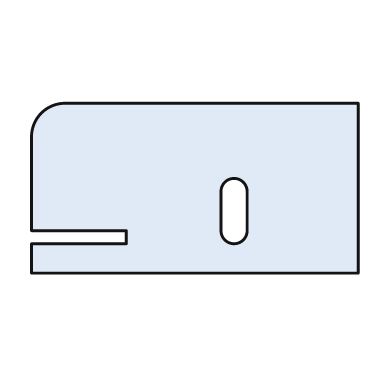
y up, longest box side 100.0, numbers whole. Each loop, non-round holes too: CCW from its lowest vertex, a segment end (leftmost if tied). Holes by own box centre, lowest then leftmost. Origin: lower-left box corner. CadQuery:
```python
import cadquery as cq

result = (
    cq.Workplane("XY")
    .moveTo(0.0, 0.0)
    .lineTo(100.0, 0.0)
    .lineTo(100.0, 52.0)
    .lineTo(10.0, 52.0)
    .threePointArc((3.0, 49.0), (0.0, 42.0))
    .lineTo(0.0, 13.0)
    .lineTo(29.0, 13.0)
    .lineTo(29.0, 9.0)
    .lineTo(0.0, 9.0)
    .close()
    .moveTo(58.0, 13.0)
    .threePointArc((62.0, 9.0), (66.0, 13.0))
    .lineTo(66.0, 25.0)
    .threePointArc((62.0, 29.0), (58.0, 25.0))
    .close()
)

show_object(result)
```